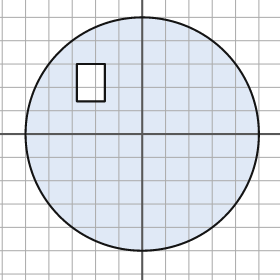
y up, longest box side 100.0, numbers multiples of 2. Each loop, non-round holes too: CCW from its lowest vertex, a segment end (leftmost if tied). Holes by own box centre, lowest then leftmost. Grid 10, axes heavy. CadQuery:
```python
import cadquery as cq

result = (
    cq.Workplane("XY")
    .moveTo(0.0, 0.0)
    .circle(50.0)
    .moveTo(-28.0, 14.0)
    .lineTo(-16.0, 14.0)
    .lineTo(-16.0, 30.0)
    .lineTo(-28.0, 30.0)
    .close()
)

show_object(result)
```